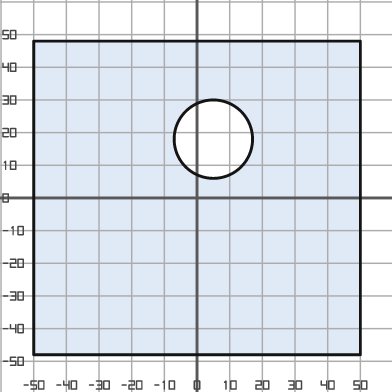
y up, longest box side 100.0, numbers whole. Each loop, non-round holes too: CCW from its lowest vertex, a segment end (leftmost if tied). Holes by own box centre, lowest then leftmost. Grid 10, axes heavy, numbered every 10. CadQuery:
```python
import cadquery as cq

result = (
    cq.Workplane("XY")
    .moveTo(-50.0, -48.0)
    .lineTo(50.0, -48.0)
    .lineTo(50.0, 48.0)
    .lineTo(-50.0, 48.0)
    .close()
    .moveTo(5.0, 18.0)
    .circle(12.0)
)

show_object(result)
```